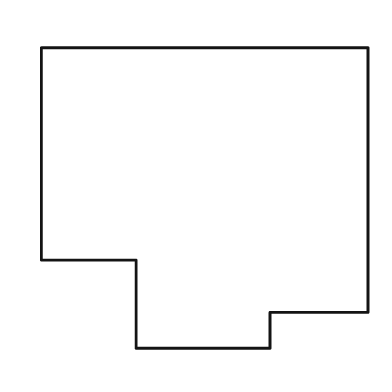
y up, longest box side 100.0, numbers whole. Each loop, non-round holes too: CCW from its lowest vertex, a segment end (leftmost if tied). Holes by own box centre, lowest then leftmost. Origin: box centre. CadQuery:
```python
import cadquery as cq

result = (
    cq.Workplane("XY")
    .moveTo(-21.0, -46.0)
    .lineTo(20.0, -46.0)
    .lineTo(20.0, -35.0)
    .lineTo(50.0, -35.0)
    .lineTo(50.0, 46.0)
    .lineTo(-50.0, 46.0)
    .lineTo(-50.0, -19.0)
    .lineTo(-21.0, -19.0)
    .close()
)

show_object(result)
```